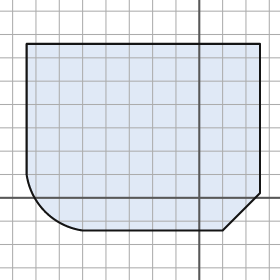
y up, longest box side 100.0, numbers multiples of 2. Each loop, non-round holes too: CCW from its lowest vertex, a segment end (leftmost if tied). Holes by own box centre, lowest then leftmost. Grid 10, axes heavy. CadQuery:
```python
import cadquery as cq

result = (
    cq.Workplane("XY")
    .moveTo(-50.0, -14.0)
    .lineTo(10.0, -14.0)
    .lineTo(26.0, 2.0)
    .lineTo(26.0, 66.0)
    .lineTo(-74.0, 66.0)
    .lineTo(-74.0, 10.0)
    .threePointArc((-66.0, -6.0), (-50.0, -14.0))
    .close()
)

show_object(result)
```